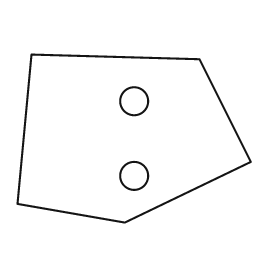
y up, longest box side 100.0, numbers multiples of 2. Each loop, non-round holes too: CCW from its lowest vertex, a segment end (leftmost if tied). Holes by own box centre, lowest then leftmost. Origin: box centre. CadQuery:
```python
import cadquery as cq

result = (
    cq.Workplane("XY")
    .moveTo(-4.0, -36.0)
    .lineTo(50.0, -10.0)
    .lineTo(28.0, 34.0)
    .lineTo(-44.0, 36.0)
    .lineTo(-50.0, -28.0)
    .close()
    .moveTo(0.0, -16.0)
    .circle(6.0)
    .moveTo(0.0, 16.0)
    .circle(6.0)
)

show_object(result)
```